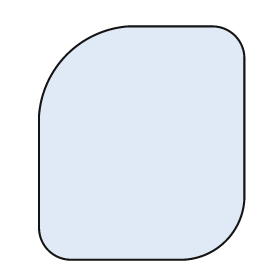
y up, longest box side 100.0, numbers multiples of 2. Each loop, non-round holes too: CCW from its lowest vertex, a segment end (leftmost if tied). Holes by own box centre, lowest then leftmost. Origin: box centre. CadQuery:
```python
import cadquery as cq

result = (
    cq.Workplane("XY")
    .moveTo(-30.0, -50.0)
    .lineTo(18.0, -50.0)
    .threePointArc((36.0, -42.0), (44.0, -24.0))
    .lineTo(44.0, 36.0)
    .threePointArc((40.0, 46.0), (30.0, 50.0))
    .lineTo(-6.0, 50.0)
    .threePointArc((-32.0, 38.0), (-44.0, 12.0))
    .lineTo(-44.0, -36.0)
    .threePointArc((-40.0, -46.0), (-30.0, -50.0))
    .close()
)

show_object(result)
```